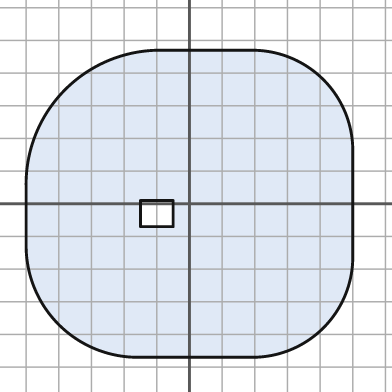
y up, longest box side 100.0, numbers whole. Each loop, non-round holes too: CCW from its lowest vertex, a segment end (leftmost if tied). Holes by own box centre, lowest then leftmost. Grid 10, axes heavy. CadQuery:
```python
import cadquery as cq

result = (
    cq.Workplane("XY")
    .moveTo(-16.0, -47.0)
    .lineTo(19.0, -47.0)
    .threePointArc((41.0, -38.0), (50.0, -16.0))
    .lineTo(50.0, 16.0)
    .threePointArc((41.0, 38.0), (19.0, 47.0))
    .lineTo(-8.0, 47.0)
    .threePointArc((-38.0, 35.0), (-50.0, 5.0))
    .lineTo(-50.0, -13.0)
    .threePointArc((-40.0, -37.0), (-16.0, -47.0))
    .close()
    .moveTo(-15.0, -7.0)
    .lineTo(-5.0, -7.0)
    .lineTo(-5.0, 1.0)
    .lineTo(-15.0, 1.0)
    .close()
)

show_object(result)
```